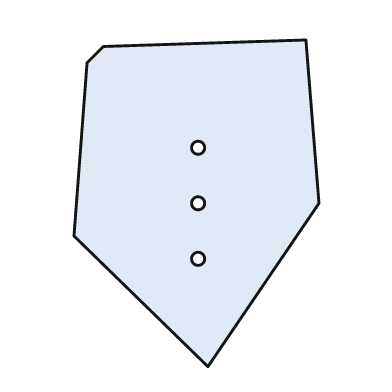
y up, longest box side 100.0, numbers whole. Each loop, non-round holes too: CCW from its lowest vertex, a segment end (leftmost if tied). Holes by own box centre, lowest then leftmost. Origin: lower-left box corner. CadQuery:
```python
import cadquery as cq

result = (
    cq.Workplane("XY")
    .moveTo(41.0, 0.0)
    .lineTo(75.0, 50.0)
    .lineTo(71.0, 100.0)
    .lineTo(9.0, 98.0)
    .lineTo(4.0, 93.0)
    .lineTo(0.0, 40.0)
    .close()
    .moveTo(38.0, 33.0)
    .circle(2.0)
    .moveTo(38.0, 50.0)
    .circle(2.0)
    .moveTo(38.0, 67.0)
    .circle(2.0)
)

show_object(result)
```